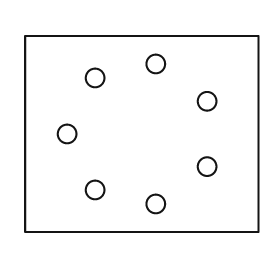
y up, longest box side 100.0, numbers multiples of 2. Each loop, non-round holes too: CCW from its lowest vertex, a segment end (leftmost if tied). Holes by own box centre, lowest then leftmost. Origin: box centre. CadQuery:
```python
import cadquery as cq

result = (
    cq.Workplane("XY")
    .moveTo(-50.0, -42.0)
    .lineTo(50.0, -42.0)
    .lineTo(50.0, 42.0)
    .lineTo(-50.0, 42.0)
    .close()
    .moveTo(6.0, -30.0)
    .circle(4.0)
    .moveTo(-20.0, -24.0)
    .circle(4.0)
    .moveTo(28.0, -14.0)
    .circle(4.0)
    .moveTo(-32.0, 0.0)
    .circle(4.0)
    .moveTo(28.0, 14.0)
    .circle(4.0)
    .moveTo(-20.0, 24.0)
    .circle(4.0)
    .moveTo(6.0, 30.0)
    .circle(4.0)
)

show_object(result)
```